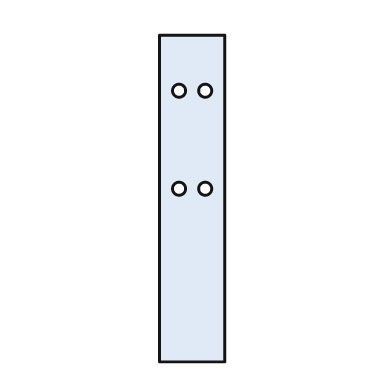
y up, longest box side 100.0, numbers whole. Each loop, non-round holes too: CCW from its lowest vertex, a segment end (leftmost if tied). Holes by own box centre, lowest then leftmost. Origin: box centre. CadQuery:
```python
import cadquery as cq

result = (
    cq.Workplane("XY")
    .moveTo(-10.0, -50.0)
    .lineTo(10.0, -50.0)
    .lineTo(10.0, 50.0)
    .lineTo(-10.0, 50.0)
    .close()
    .moveTo(-4.0, 3.0)
    .circle(2.0)
    .moveTo(4.0, 3.0)
    .circle(2.0)
    .moveTo(-4.0, 33.0)
    .circle(2.0)
    .moveTo(4.0, 33.0)
    .circle(2.0)
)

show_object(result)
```